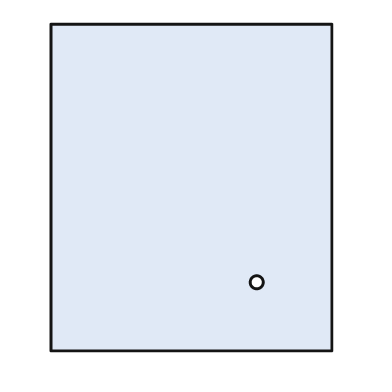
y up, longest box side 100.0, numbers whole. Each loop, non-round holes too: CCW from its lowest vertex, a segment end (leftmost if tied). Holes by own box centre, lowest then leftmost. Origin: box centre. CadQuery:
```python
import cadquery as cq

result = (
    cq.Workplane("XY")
    .moveTo(-43.0, -50.0)
    .lineTo(43.0, -50.0)
    .lineTo(43.0, 50.0)
    .lineTo(-43.0, 50.0)
    .close()
    .moveTo(20.0, -29.0)
    .circle(2.0)
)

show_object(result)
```